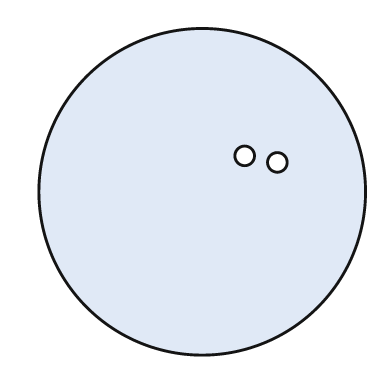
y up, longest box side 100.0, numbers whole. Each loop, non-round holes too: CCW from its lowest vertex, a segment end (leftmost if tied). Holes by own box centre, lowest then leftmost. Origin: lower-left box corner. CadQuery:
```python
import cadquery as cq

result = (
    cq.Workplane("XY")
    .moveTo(50.0, 50.0)
    .circle(50.0)
    .moveTo(73.0, 59.0)
    .circle(3.0)
    .moveTo(63.0, 61.0)
    .circle(3.0)
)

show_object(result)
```